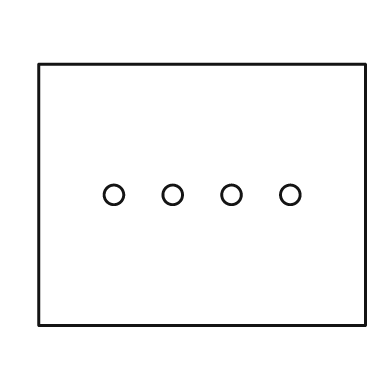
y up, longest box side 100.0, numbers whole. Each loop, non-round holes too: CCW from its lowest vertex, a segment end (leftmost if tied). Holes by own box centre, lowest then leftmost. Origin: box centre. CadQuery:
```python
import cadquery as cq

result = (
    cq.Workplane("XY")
    .moveTo(-50.0, -40.0)
    .lineTo(50.0, -40.0)
    .lineTo(50.0, 40.0)
    .lineTo(-50.0, 40.0)
    .close()
    .moveTo(-27.0, 0.0)
    .circle(3.0)
    .moveTo(-9.0, 0.0)
    .circle(3.0)
    .moveTo(9.0, 0.0)
    .circle(3.0)
    .moveTo(27.0, 0.0)
    .circle(3.0)
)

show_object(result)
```